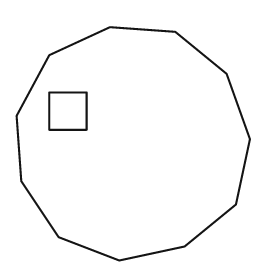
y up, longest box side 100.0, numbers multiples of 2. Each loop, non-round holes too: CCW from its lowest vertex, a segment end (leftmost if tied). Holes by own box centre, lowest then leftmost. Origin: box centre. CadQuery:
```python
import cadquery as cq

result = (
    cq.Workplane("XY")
    .moveTo(-6.0, -50.0)
    .lineTo(22.0, -44.0)
    .lineTo(44.0, -26.0)
    .lineTo(50.0, 2.0)
    .lineTo(40.0, 30.0)
    .lineTo(18.0, 48.0)
    .lineTo(-10.0, 50.0)
    .lineTo(-36.0, 38.0)
    .lineTo(-50.0, 12.0)
    .lineTo(-48.0, -16.0)
    .lineTo(-32.0, -40.0)
    .close()
    .moveTo(-36.0, 6.0)
    .lineTo(-20.0, 6.0)
    .lineTo(-20.0, 22.0)
    .lineTo(-36.0, 22.0)
    .close()
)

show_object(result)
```